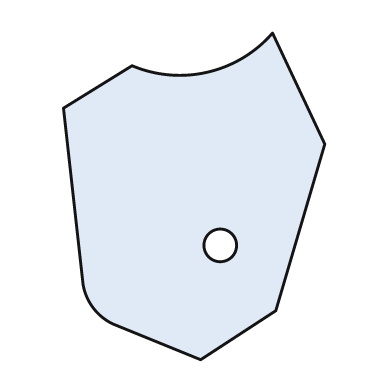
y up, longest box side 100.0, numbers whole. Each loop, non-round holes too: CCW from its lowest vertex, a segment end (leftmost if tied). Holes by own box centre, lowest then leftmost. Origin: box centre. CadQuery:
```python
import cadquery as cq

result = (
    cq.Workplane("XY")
    .moveTo(2.0, -50.0)
    .lineTo(25.0, -35.0)
    .lineTo(40.0, 16.0)
    .lineTo(24.0, 50.0)
    .threePointArc((4.0, 38.0), (-19.0, 40.0))
    .lineTo(-40.0, 27.0)
    .lineTo(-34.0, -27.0)
    .threePointArc((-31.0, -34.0), (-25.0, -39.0))
    .close()
    .moveTo(8.0, -15.0)
    .circle(5.0)
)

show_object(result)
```